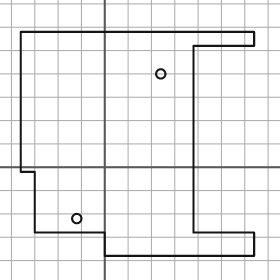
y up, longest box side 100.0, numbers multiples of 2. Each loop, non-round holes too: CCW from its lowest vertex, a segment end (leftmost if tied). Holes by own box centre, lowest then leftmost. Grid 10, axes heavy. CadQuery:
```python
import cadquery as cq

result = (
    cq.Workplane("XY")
    .moveTo(0.0, -38.0)
    .lineTo(64.0, -38.0)
    .lineTo(64.0, -28.0)
    .lineTo(38.0, -28.0)
    .lineTo(38.0, 52.0)
    .lineTo(64.0, 52.0)
    .lineTo(64.0, 58.0)
    .lineTo(-36.0, 58.0)
    .lineTo(-36.0, -2.0)
    .lineTo(-30.0, -2.0)
    .lineTo(-30.0, -28.0)
    .lineTo(0.0, -28.0)
    .close()
    .moveTo(-12.0, -22.0)
    .circle(2.0)
    .moveTo(24.0, 40.0)
    .circle(2.0)
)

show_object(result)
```